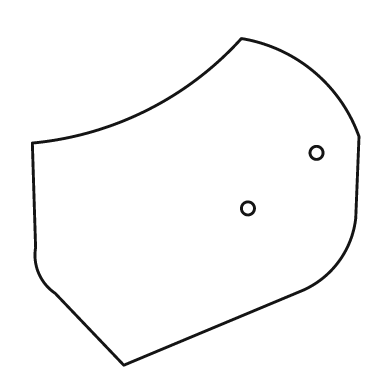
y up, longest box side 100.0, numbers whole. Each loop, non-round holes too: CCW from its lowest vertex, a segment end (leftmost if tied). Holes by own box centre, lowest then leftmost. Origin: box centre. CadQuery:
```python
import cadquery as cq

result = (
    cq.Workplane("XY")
    .moveTo(-22.0, -50.0)
    .lineTo(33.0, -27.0)
    .threePointArc((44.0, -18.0), (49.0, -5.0))
    .lineTo(50.0, 20.0)
    .threePointArc((36.0, 40.0), (14.0, 50.0))
    .threePointArc((-15.0, 28.0), (-50.0, 18.0))
    .lineTo(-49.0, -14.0)
    .threePointArc((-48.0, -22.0), (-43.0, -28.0))
    .close()
    .moveTo(16.0, -2.0)
    .circle(2.0)
    .moveTo(37.0, 15.0)
    .circle(2.0)
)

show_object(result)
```